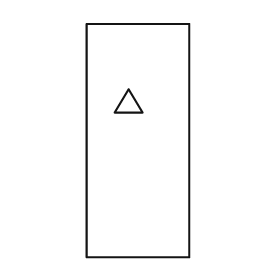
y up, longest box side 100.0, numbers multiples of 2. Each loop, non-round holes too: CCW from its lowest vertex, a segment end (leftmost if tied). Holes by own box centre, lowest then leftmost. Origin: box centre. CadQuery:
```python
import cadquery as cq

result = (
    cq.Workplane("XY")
    .moveTo(-22.0, -50.0)
    .lineTo(22.0, -50.0)
    .lineTo(22.0, 50.0)
    .lineTo(-22.0, 50.0)
    .close()
    .moveTo(-10.0, 12.0)
    .lineTo(2.0, 12.0)
    .lineTo(-4.0, 22.0)
    .close()
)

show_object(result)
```